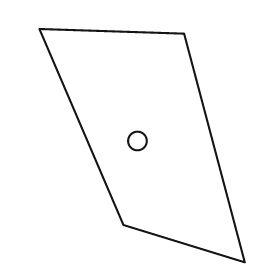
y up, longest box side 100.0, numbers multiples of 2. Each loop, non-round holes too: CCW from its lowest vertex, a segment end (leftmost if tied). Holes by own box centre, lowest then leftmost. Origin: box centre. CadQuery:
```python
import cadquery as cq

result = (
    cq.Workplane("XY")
    .moveTo(44.0, -50.0)
    .lineTo(18.0, 48.0)
    .lineTo(-44.0, 50.0)
    .lineTo(-8.0, -34.0)
    .close()
    .moveTo(-2.0, 2.0)
    .circle(4.0)
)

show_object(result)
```